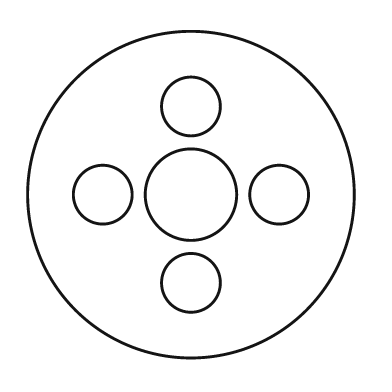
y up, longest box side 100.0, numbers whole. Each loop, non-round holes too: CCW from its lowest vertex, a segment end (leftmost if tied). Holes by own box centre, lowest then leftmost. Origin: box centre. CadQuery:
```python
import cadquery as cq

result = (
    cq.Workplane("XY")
    .moveTo(0.0, 0.0)
    .circle(50.0)
    .moveTo(0.0, -27.0)
    .circle(9.0)
    .moveTo(-27.0, 0.0)
    .circle(9.0)
    .moveTo(0.0, 0.0)
    .circle(14.0)
    .moveTo(27.0, 0.0)
    .circle(9.0)
    .moveTo(0.0, 27.0)
    .circle(9.0)
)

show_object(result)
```